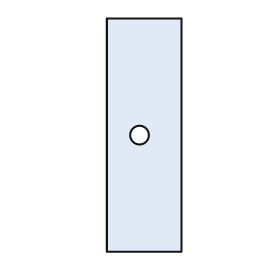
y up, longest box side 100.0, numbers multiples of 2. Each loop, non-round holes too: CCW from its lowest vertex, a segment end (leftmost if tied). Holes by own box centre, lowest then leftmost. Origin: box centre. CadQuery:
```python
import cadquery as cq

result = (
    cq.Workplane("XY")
    .moveTo(-16.0, -50.0)
    .lineTo(16.0, -50.0)
    .lineTo(16.0, 50.0)
    .lineTo(-16.0, 50.0)
    .close()
    .moveTo(-2.0, 0.0)
    .circle(4.0)
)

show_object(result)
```